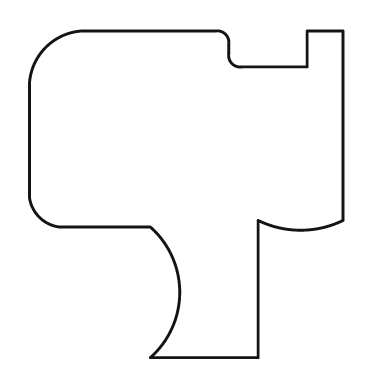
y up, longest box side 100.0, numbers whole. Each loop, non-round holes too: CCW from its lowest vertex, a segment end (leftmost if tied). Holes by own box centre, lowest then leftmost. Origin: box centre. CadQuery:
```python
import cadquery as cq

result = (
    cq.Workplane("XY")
    .moveTo(-11.0, -50.0)
    .lineTo(22.0, -50.0)
    .lineTo(22.0, -8.0)
    .threePointArc((35.0, -11.0), (48.0, -8.0))
    .lineTo(48.0, 50.0)
    .lineTo(37.0, 50.0)
    .lineTo(37.0, 39.0)
    .lineTo(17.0, 39.0)
    .threePointArc((14.0, 40.0), (13.0, 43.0))
    .lineTo(13.0, 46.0)
    .threePointArc((12.0, 49.0), (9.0, 50.0))
    .lineTo(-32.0, 50.0)
    .threePointArc((-43.0, 45.0), (-48.0, 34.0))
    .lineTo(-48.0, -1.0)
    .threePointArc((-45.0, -7.0), (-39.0, -10.0))
    .lineTo(-11.0, -10.0)
    .threePointArc((-2.0, -30.0), (-11.0, -50.0))
    .close()
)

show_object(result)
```